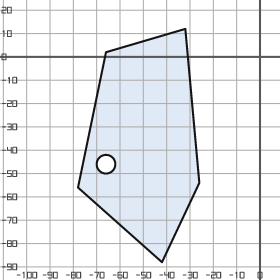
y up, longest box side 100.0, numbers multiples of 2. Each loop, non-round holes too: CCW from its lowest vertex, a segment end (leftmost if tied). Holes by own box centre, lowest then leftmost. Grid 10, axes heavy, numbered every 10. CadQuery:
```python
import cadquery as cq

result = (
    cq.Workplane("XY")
    .moveTo(-42.0, -88.0)
    .lineTo(-26.0, -54.0)
    .lineTo(-32.0, 12.0)
    .lineTo(-66.0, 2.0)
    .lineTo(-78.0, -56.0)
    .close()
    .moveTo(-66.0, -46.0)
    .circle(4.0)
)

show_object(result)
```